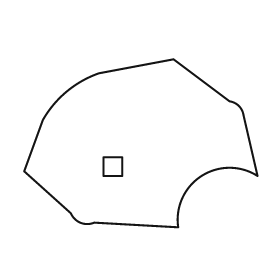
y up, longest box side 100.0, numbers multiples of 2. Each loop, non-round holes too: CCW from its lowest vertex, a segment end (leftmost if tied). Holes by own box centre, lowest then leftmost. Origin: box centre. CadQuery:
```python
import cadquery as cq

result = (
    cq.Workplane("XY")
    .moveTo(16.0, -36.0)
    .threePointArc((26.0, -14.0), (50.0, -14.0))
    .lineTo(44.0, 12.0)
    .threePointArc((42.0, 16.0), (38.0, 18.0))
    .lineTo(14.0, 36.0)
    .lineTo(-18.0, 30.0)
    .threePointArc((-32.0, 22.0), (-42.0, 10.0))
    .lineTo(-50.0, -12.0)
    .lineTo(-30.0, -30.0)
    .threePointArc((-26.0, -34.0), (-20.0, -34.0))
    .close()
    .moveTo(-16.0, -14.0)
    .lineTo(-8.0, -14.0)
    .lineTo(-8.0, -6.0)
    .lineTo(-16.0, -6.0)
    .close()
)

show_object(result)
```